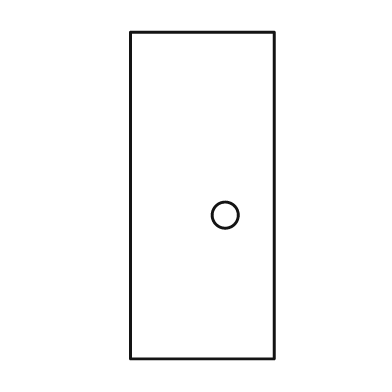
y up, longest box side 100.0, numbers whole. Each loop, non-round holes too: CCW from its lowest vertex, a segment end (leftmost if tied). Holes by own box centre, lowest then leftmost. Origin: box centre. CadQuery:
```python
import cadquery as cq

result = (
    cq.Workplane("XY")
    .moveTo(-22.0, -50.0)
    .lineTo(22.0, -50.0)
    .lineTo(22.0, 50.0)
    .lineTo(-22.0, 50.0)
    .close()
    .moveTo(7.0, -6.0)
    .circle(4.0)
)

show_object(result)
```